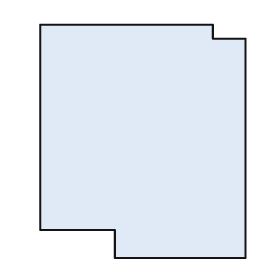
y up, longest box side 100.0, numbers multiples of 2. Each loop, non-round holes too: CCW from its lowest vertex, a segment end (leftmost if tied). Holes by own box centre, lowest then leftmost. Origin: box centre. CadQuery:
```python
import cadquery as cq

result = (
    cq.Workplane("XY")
    .moveTo(-12.0, -50.0)
    .lineTo(44.0, -50.0)
    .lineTo(44.0, 44.0)
    .lineTo(30.0, 44.0)
    .lineTo(30.0, 50.0)
    .lineTo(-44.0, 50.0)
    .lineTo(-44.0, -38.0)
    .lineTo(-12.0, -38.0)
    .close()
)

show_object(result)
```